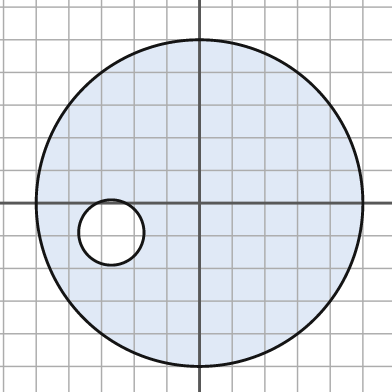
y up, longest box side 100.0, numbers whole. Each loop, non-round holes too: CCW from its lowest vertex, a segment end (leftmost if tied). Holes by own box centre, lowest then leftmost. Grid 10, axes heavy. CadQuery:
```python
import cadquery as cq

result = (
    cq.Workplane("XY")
    .moveTo(0.0, 0.0)
    .circle(50.0)
    .moveTo(-27.0, -9.0)
    .circle(10.0)
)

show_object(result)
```